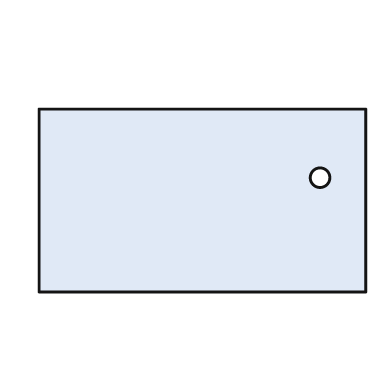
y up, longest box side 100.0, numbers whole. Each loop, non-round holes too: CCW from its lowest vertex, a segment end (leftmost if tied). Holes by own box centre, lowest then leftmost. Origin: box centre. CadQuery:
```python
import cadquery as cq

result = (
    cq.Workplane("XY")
    .moveTo(-50.0, -28.0)
    .lineTo(50.0, -28.0)
    .lineTo(50.0, 28.0)
    .lineTo(-50.0, 28.0)
    .close()
    .moveTo(36.0, 7.0)
    .circle(3.0)
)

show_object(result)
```